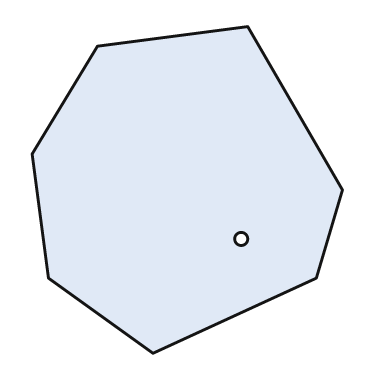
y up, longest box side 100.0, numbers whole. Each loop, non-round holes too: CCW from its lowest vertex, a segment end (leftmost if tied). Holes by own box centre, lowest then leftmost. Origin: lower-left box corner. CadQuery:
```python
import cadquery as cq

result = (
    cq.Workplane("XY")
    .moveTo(37.0, 0.0)
    .lineTo(87.0, 23.0)
    .lineTo(95.0, 50.0)
    .lineTo(66.0, 100.0)
    .lineTo(20.0, 94.0)
    .lineTo(0.0, 61.0)
    .lineTo(5.0, 23.0)
    .close()
    .moveTo(64.0, 35.0)
    .circle(2.0)
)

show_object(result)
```